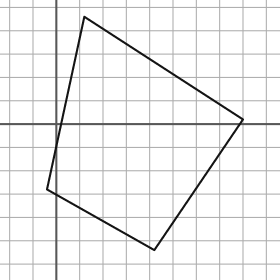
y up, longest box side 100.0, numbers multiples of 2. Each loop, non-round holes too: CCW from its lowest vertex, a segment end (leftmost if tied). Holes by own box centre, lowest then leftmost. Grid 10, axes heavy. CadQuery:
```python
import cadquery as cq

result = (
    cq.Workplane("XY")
    .moveTo(42.0, -54.0)
    .lineTo(80.0, 2.0)
    .lineTo(12.0, 46.0)
    .lineTo(-4.0, -28.0)
    .close()
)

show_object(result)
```